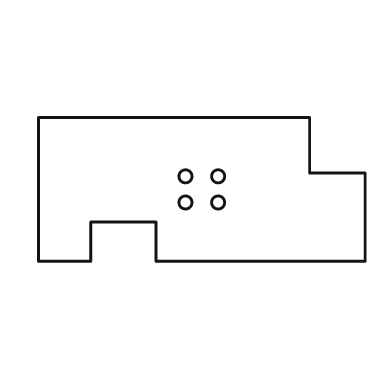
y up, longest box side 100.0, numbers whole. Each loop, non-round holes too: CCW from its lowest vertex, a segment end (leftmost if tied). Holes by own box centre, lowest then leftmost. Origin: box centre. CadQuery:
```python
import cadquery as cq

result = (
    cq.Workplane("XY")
    .moveTo(-50.0, -22.0)
    .lineTo(-34.0, -22.0)
    .lineTo(-34.0, -10.0)
    .lineTo(-14.0, -10.0)
    .lineTo(-14.0, -22.0)
    .lineTo(50.0, -22.0)
    .lineTo(50.0, 5.0)
    .lineTo(33.0, 5.0)
    .lineTo(33.0, 22.0)
    .lineTo(-50.0, 22.0)
    .close()
    .moveTo(-5.0, -4.0)
    .circle(2.0)
    .moveTo(5.0, -4.0)
    .circle(2.0)
    .moveTo(-5.0, 4.0)
    .circle(2.0)
    .moveTo(5.0, 4.0)
    .circle(2.0)
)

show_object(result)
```